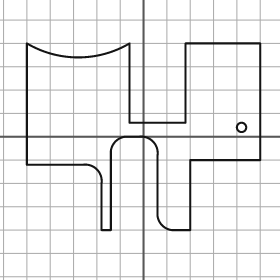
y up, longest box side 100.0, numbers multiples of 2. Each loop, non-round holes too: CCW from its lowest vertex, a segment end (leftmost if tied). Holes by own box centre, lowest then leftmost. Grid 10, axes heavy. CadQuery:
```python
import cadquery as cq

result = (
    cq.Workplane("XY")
    .moveTo(-18.0, -40.0)
    .lineTo(-14.0, -40.0)
    .lineTo(-14.0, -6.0)
    .threePointArc((-12.0, -2.0), (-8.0, 0.0))
    .lineTo(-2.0, 0.0)
    .threePointArc((4.0, -2.0), (6.0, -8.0))
    .lineTo(6.0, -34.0)
    .threePointArc((8.0, -38.0), (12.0, -40.0))
    .lineTo(20.0, -40.0)
    .lineTo(20.0, -10.0)
    .lineTo(50.0, -10.0)
    .lineTo(50.0, 40.0)
    .lineTo(18.0, 40.0)
    .lineTo(18.0, 6.0)
    .lineTo(-6.0, 6.0)
    .lineTo(-6.0, 40.0)
    .threePointArc((-28.0, 34.0), (-50.0, 40.0))
    .lineTo(-50.0, -12.0)
    .lineTo(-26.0, -12.0)
    .threePointArc((-20.0, -14.0), (-18.0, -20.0))
    .close()
    .moveTo(42.0, 4.0)
    .circle(2.0)
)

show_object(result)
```